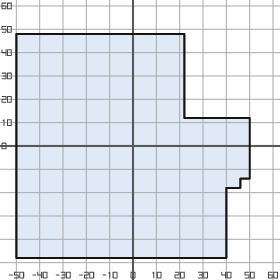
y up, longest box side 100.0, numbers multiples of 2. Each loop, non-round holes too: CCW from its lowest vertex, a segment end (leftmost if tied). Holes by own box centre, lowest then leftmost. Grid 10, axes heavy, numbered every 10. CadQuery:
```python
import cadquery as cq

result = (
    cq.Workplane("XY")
    .moveTo(-50.0, -48.0)
    .lineTo(40.0, -48.0)
    .lineTo(40.0, -18.0)
    .lineTo(46.0, -18.0)
    .lineTo(46.0, -14.0)
    .lineTo(50.0, -14.0)
    .lineTo(50.0, 12.0)
    .lineTo(22.0, 12.0)
    .lineTo(22.0, 48.0)
    .lineTo(-50.0, 48.0)
    .close()
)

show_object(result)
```